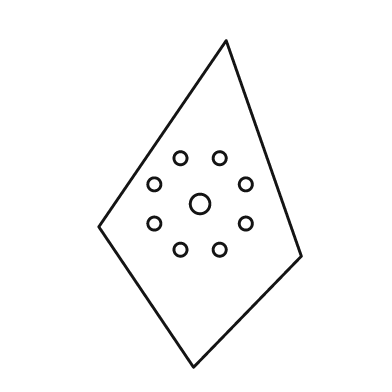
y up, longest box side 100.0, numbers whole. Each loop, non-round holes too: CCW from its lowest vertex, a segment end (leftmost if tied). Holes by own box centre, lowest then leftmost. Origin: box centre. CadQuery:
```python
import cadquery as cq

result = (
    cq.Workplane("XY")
    .moveTo(-2.0, -50.0)
    .lineTo(31.0, -16.0)
    .lineTo(8.0, 50.0)
    .lineTo(-31.0, -7.0)
    .close()
    .moveTo(-6.0, -14.0)
    .circle(2.0)
    .moveTo(6.0, -14.0)
    .circle(2.0)
    .moveTo(-14.0, -6.0)
    .circle(2.0)
    .moveTo(14.0, -6.0)
    .circle(2.0)
    .moveTo(0.0, 0.0)
    .circle(3.0)
    .moveTo(-14.0, 6.0)
    .circle(2.0)
    .moveTo(14.0, 6.0)
    .circle(2.0)
    .moveTo(-6.0, 14.0)
    .circle(2.0)
    .moveTo(6.0, 14.0)
    .circle(2.0)
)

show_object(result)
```